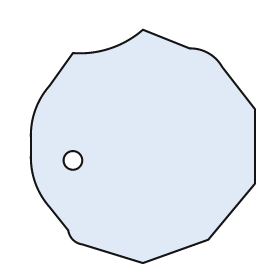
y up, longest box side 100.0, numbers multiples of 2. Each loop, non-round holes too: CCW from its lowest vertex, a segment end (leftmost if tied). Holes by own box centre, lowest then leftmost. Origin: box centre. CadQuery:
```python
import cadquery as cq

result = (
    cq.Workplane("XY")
    .moveTo(0.0, -50.0)
    .lineTo(28.0, -40.0)
    .lineTo(48.0, -16.0)
    .lineTo(48.0, 16.0)
    .lineTo(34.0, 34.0)
    .threePointArc((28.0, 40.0), (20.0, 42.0))
    .lineTo(0.0, 50.0)
    .threePointArc((-14.0, 42.0), (-30.0, 40.0))
    .lineTo(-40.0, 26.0)
    .threePointArc((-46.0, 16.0), (-48.0, 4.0))
    .lineTo(-48.0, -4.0)
    .threePointArc((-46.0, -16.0), (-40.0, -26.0))
    .lineTo(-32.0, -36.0)
    .threePointArc((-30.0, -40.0), (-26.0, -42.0))
    .close()
    .moveTo(-30.0, -6.0)
    .circle(4.0)
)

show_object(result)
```